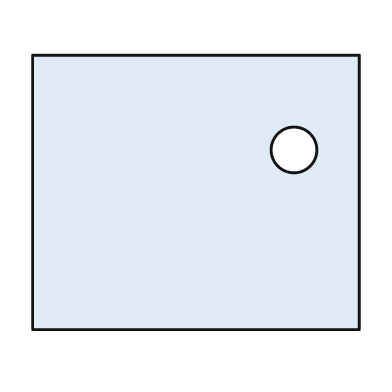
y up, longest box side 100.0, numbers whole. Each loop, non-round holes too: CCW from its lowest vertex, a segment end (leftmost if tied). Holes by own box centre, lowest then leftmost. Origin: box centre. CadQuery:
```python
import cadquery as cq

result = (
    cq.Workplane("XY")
    .moveTo(-50.0, -42.0)
    .lineTo(50.0, -42.0)
    .lineTo(50.0, 42.0)
    .lineTo(-50.0, 42.0)
    .close()
    .moveTo(30.0, 13.0)
    .circle(7.0)
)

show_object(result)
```